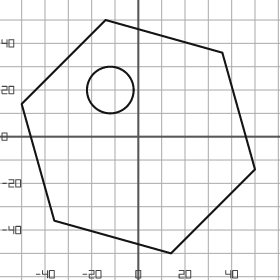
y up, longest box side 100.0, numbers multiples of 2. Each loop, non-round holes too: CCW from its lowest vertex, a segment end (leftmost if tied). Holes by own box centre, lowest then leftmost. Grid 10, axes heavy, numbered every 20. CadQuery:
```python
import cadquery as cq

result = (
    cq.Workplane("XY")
    .moveTo(14.0, -50.0)
    .lineTo(50.0, -14.0)
    .lineTo(36.0, 36.0)
    .lineTo(-14.0, 50.0)
    .lineTo(-50.0, 14.0)
    .lineTo(-36.0, -36.0)
    .close()
    .moveTo(-12.0, 20.0)
    .circle(10.0)
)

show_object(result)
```